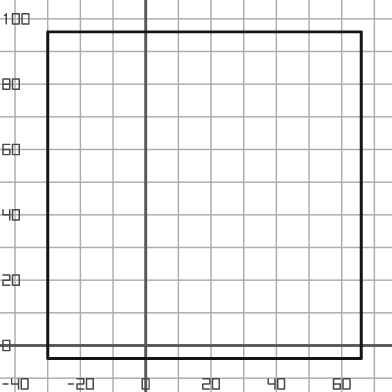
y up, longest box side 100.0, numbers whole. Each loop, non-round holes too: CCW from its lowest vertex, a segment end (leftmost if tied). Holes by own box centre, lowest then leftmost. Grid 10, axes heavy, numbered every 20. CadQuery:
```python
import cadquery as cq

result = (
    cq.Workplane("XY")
    .moveTo(-30.0, -4.0)
    .lineTo(66.0, -4.0)
    .lineTo(66.0, 96.0)
    .lineTo(-30.0, 96.0)
    .close()
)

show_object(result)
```